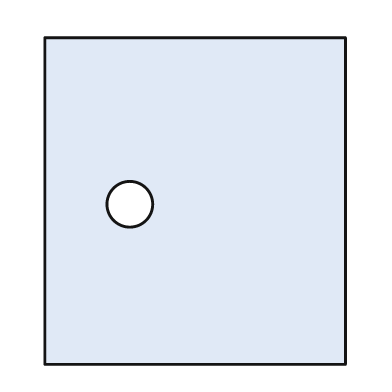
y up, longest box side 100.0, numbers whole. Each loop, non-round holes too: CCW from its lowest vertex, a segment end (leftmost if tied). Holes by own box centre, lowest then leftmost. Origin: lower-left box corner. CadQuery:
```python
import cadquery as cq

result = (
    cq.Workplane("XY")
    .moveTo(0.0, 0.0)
    .lineTo(92.0, 0.0)
    .lineTo(92.0, 100.0)
    .lineTo(0.0, 100.0)
    .close()
    .moveTo(26.0, 49.0)
    .circle(7.0)
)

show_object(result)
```